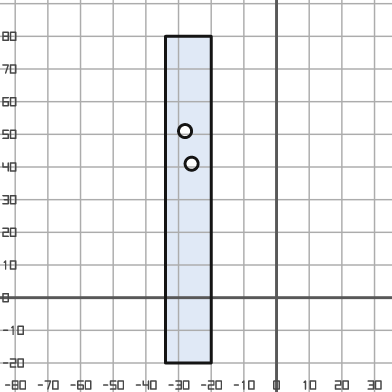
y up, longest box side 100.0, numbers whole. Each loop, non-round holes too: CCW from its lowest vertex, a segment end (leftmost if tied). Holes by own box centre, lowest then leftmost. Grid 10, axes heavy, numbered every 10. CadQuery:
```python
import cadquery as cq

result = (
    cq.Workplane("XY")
    .moveTo(-34.0, -20.0)
    .lineTo(-20.0, -20.0)
    .lineTo(-20.0, 80.0)
    .lineTo(-34.0, 80.0)
    .close()
    .moveTo(-26.0, 41.0)
    .circle(2.0)
    .moveTo(-28.0, 51.0)
    .circle(2.0)
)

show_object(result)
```